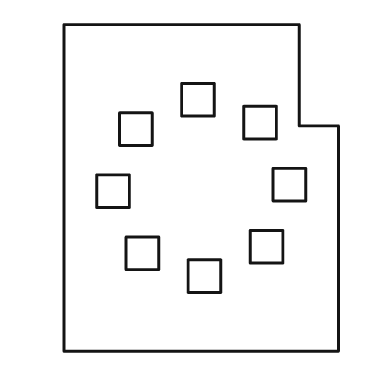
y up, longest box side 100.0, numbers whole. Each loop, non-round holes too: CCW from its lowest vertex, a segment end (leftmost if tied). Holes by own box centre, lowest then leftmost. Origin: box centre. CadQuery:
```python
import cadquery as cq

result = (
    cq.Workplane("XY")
    .moveTo(-42.0, -50.0)
    .lineTo(42.0, -50.0)
    .lineTo(42.0, 19.0)
    .lineTo(30.0, 19.0)
    .lineTo(30.0, 50.0)
    .lineTo(-42.0, 50.0)
    .close()
    .moveTo(-4.0, -32.0)
    .lineTo(6.0, -32.0)
    .lineTo(6.0, -22.0)
    .lineTo(-4.0, -22.0)
    .close()
    .moveTo(-23.0, -25.0)
    .lineTo(-13.0, -25.0)
    .lineTo(-13.0, -15.0)
    .lineTo(-23.0, -15.0)
    .close()
    .moveTo(15.0, -23.0)
    .lineTo(25.0, -23.0)
    .lineTo(25.0, -13.0)
    .lineTo(15.0, -13.0)
    .close()
    .moveTo(-32.0, -6.0)
    .lineTo(-22.0, -6.0)
    .lineTo(-22.0, 4.0)
    .lineTo(-32.0, 4.0)
    .close()
    .moveTo(22.0, -4.0)
    .lineTo(32.0, -4.0)
    .lineTo(32.0, 6.0)
    .lineTo(22.0, 6.0)
    .close()
    .moveTo(-25.0, 13.0)
    .lineTo(-15.0, 13.0)
    .lineTo(-15.0, 23.0)
    .lineTo(-25.0, 23.0)
    .close()
    .moveTo(13.0, 15.0)
    .lineTo(23.0, 15.0)
    .lineTo(23.0, 25.0)
    .lineTo(13.0, 25.0)
    .close()
    .moveTo(-6.0, 22.0)
    .lineTo(4.0, 22.0)
    .lineTo(4.0, 32.0)
    .lineTo(-6.0, 32.0)
    .close()
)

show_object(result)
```